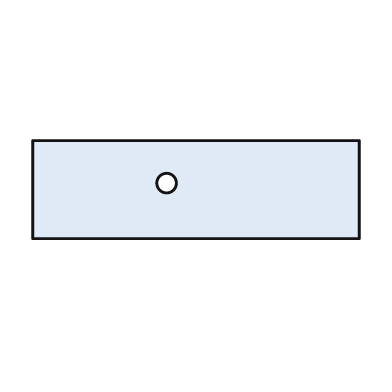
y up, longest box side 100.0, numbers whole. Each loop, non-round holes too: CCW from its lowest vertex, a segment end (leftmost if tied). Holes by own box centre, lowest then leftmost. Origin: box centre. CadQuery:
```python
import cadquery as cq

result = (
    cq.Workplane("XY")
    .moveTo(-50.0, -15.0)
    .lineTo(50.0, -15.0)
    .lineTo(50.0, 15.0)
    .lineTo(-50.0, 15.0)
    .close()
    .moveTo(-9.0, 2.0)
    .circle(3.0)
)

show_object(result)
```